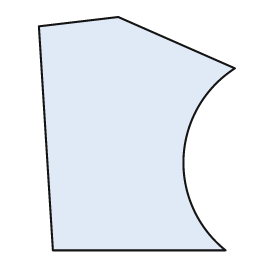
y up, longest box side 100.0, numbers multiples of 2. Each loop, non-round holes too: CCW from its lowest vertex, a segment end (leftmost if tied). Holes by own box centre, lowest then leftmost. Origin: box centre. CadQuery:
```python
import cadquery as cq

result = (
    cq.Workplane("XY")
    .moveTo(-36.0, -50.0)
    .lineTo(38.0, -50.0)
    .threePointArc((20.0, -10.0), (42.0, 28.0))
    .lineTo(-8.0, 50.0)
    .lineTo(-42.0, 46.0)
    .close()
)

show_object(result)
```